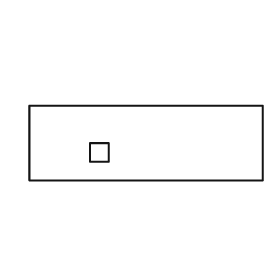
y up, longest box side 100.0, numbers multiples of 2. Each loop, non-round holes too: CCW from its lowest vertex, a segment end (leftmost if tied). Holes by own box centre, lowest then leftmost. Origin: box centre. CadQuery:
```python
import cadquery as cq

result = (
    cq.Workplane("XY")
    .moveTo(-50.0, -16.0)
    .lineTo(50.0, -16.0)
    .lineTo(50.0, 16.0)
    .lineTo(-50.0, 16.0)
    .close()
    .moveTo(-24.0, -8.0)
    .lineTo(-16.0, -8.0)
    .lineTo(-16.0, 0.0)
    .lineTo(-24.0, 0.0)
    .close()
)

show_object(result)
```